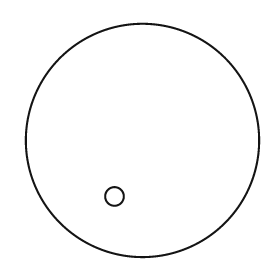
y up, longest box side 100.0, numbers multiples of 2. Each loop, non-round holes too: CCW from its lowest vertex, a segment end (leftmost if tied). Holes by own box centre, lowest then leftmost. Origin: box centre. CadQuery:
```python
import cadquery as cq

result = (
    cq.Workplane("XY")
    .moveTo(0.0, 0.0)
    .circle(50.0)
    .moveTo(-12.0, -24.0)
    .circle(4.0)
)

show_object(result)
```